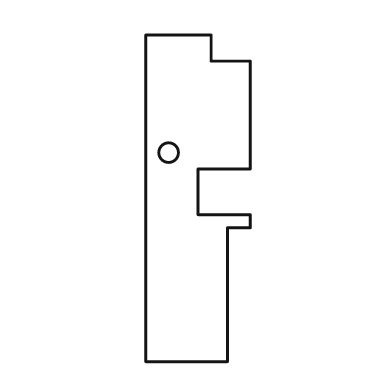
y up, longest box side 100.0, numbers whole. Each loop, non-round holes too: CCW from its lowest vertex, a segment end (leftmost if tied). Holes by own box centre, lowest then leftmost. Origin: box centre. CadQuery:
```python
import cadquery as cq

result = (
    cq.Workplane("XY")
    .moveTo(-16.0, -50.0)
    .lineTo(9.0, -50.0)
    .lineTo(9.0, -9.0)
    .lineTo(16.0, -9.0)
    .lineTo(16.0, -5.0)
    .lineTo(0.0, -5.0)
    .lineTo(0.0, 9.0)
    .lineTo(16.0, 9.0)
    .lineTo(16.0, 42.0)
    .lineTo(4.0, 42.0)
    .lineTo(4.0, 50.0)
    .lineTo(-16.0, 50.0)
    .close()
    .moveTo(-9.0, 14.0)
    .circle(3.0)
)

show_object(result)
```